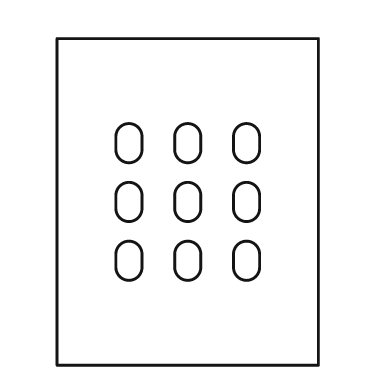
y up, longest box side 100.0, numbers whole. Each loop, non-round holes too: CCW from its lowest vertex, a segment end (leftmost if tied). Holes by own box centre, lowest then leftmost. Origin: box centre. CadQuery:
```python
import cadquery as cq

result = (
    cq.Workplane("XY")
    .moveTo(-40.0, -50.0)
    .lineTo(40.0, -50.0)
    .lineTo(40.0, 50.0)
    .lineTo(-40.0, 50.0)
    .close()
    .moveTo(-22.0, -20.0)
    .threePointArc((-18.0, -24.0), (-14.0, -20.0))
    .lineTo(-14.0, -16.0)
    .threePointArc((-18.0, -12.0), (-22.0, -16.0))
    .close()
    .moveTo(-4.0, -20.0)
    .threePointArc((0.0, -24.0), (4.0, -20.0))
    .lineTo(4.0, -16.0)
    .threePointArc((0.0, -12.0), (-4.0, -16.0))
    .close()
    .moveTo(14.0, -20.0)
    .threePointArc((18.0, -24.0), (22.0, -20.0))
    .lineTo(22.0, -16.0)
    .threePointArc((18.0, -12.0), (14.0, -16.0))
    .close()
    .moveTo(-22.0, -2.0)
    .threePointArc((-18.0, -6.0), (-14.0, -2.0))
    .lineTo(-14.0, 2.0)
    .threePointArc((-18.0, 6.0), (-22.0, 2.0))
    .close()
    .moveTo(-4.0, -2.0)
    .threePointArc((0.0, -6.0), (4.0, -2.0))
    .lineTo(4.0, 2.0)
    .threePointArc((0.0, 6.0), (-4.0, 2.0))
    .close()
    .moveTo(14.0, -2.0)
    .threePointArc((18.0, -6.0), (22.0, -2.0))
    .lineTo(22.0, 2.0)
    .threePointArc((18.0, 6.0), (14.0, 2.0))
    .close()
    .moveTo(-22.0, 16.0)
    .threePointArc((-18.0, 12.0), (-14.0, 16.0))
    .lineTo(-14.0, 20.0)
    .threePointArc((-18.0, 24.0), (-22.0, 20.0))
    .close()
    .moveTo(-4.0, 16.0)
    .threePointArc((0.0, 12.0), (4.0, 16.0))
    .lineTo(4.0, 20.0)
    .threePointArc((0.0, 24.0), (-4.0, 20.0))
    .close()
    .moveTo(14.0, 16.0)
    .threePointArc((18.0, 12.0), (22.0, 16.0))
    .lineTo(22.0, 20.0)
    .threePointArc((18.0, 24.0), (14.0, 20.0))
    .close()
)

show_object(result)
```